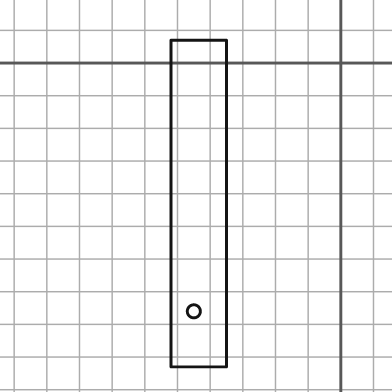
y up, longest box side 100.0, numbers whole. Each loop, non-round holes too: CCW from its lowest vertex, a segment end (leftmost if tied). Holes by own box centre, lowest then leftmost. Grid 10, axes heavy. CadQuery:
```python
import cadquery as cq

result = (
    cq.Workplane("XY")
    .moveTo(-52.0, -93.0)
    .lineTo(-35.0, -93.0)
    .lineTo(-35.0, 7.0)
    .lineTo(-52.0, 7.0)
    .close()
    .moveTo(-45.0, -76.0)
    .circle(2.0)
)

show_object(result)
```